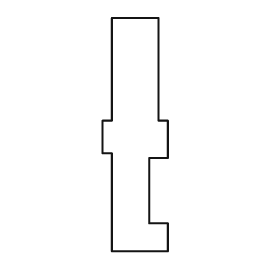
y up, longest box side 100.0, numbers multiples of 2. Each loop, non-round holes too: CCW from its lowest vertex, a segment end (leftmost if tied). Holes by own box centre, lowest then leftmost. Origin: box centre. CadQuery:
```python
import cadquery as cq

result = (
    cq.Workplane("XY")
    .moveTo(-10.0, -50.0)
    .lineTo(14.0, -50.0)
    .lineTo(14.0, -38.0)
    .lineTo(6.0, -38.0)
    .lineTo(6.0, -10.0)
    .lineTo(14.0, -10.0)
    .lineTo(14.0, 6.0)
    .lineTo(10.0, 6.0)
    .lineTo(10.0, 50.0)
    .lineTo(-10.0, 50.0)
    .lineTo(-10.0, 6.0)
    .lineTo(-14.0, 6.0)
    .lineTo(-14.0, -8.0)
    .lineTo(-10.0, -8.0)
    .close()
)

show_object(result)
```